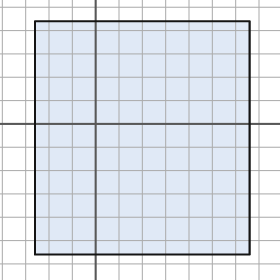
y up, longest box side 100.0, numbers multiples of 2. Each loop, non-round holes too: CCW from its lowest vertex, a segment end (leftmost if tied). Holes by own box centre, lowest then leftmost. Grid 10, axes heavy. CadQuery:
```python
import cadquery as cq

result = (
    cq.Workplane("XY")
    .moveTo(-26.0, -56.0)
    .lineTo(66.0, -56.0)
    .lineTo(66.0, 44.0)
    .lineTo(-26.0, 44.0)
    .close()
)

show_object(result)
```